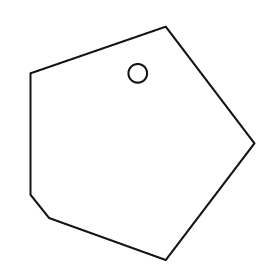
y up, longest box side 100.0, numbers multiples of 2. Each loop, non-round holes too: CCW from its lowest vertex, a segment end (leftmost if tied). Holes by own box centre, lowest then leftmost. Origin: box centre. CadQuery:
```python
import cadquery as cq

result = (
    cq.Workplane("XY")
    .moveTo(10.0, -50.0)
    .lineTo(48.0, 0.0)
    .lineTo(10.0, 50.0)
    .lineTo(-48.0, 30.0)
    .lineTo(-48.0, -22.0)
    .lineTo(-40.0, -32.0)
    .close()
    .moveTo(-2.0, 30.0)
    .circle(4.0)
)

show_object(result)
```